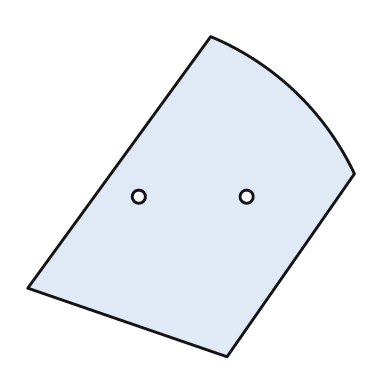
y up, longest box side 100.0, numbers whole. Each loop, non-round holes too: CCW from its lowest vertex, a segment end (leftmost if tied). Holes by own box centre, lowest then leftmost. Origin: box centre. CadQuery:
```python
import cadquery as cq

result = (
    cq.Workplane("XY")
    .moveTo(11.0, -49.0)
    .lineTo(50.0, 7.0)
    .threePointArc((32.0, 32.0), (6.0, 49.0))
    .lineTo(-50.0, -28.0)
    .close()
    .moveTo(-16.0, 0.0)
    .circle(2.0)
    .moveTo(17.0, 0.0)
    .circle(2.0)
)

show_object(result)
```